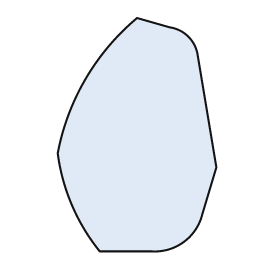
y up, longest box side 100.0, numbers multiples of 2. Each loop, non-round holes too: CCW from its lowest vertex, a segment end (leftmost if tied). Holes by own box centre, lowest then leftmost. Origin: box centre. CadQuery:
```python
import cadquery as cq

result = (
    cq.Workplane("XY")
    .moveTo(-16.0, -50.0)
    .lineTo(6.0, -50.0)
    .threePointArc((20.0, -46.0), (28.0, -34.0))
    .lineTo(34.0, -14.0)
    .lineTo(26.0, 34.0)
    .threePointArc((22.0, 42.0), (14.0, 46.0))
    .lineTo(0.0, 50.0)
    .threePointArc((-22.0, 24.0), (-34.0, -8.0))
    .threePointArc((-28.0, -30.0), (-16.0, -50.0))
    .close()
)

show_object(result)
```